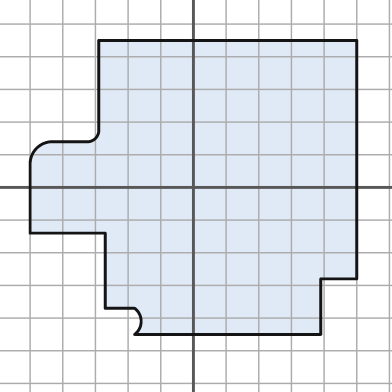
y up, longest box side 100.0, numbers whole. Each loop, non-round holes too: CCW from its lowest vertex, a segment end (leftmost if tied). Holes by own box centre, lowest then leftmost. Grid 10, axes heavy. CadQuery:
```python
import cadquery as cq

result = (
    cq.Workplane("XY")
    .moveTo(-18.0, -45.0)
    .lineTo(39.0, -45.0)
    .lineTo(39.0, -28.0)
    .lineTo(50.0, -28.0)
    .lineTo(50.0, 45.0)
    .lineTo(-29.0, 45.0)
    .lineTo(-29.0, 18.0)
    .threePointArc((-30.0, 15.0), (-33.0, 14.0))
    .lineTo(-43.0, 14.0)
    .threePointArc((-48.0, 12.0), (-50.0, 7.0))
    .lineTo(-50.0, -14.0)
    .lineTo(-27.0, -14.0)
    .lineTo(-27.0, -37.0)
    .lineTo(-18.0, -37.0)
    .threePointArc((-16.0, -41.0), (-18.0, -45.0))
    .close()
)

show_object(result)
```